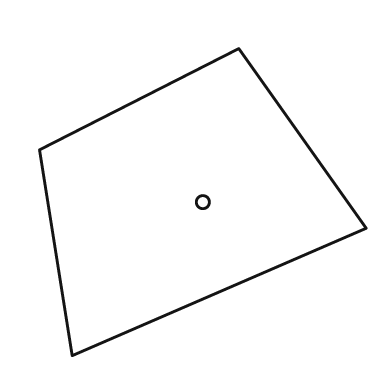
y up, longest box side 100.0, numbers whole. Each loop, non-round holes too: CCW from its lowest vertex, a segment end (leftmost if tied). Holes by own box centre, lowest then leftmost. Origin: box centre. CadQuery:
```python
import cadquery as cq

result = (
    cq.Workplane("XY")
    .moveTo(-40.0, -47.0)
    .lineTo(50.0, -8.0)
    .lineTo(11.0, 47.0)
    .lineTo(-50.0, 16.0)
    .close()
    .moveTo(0.0, 0.0)
    .circle(2.0)
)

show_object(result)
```